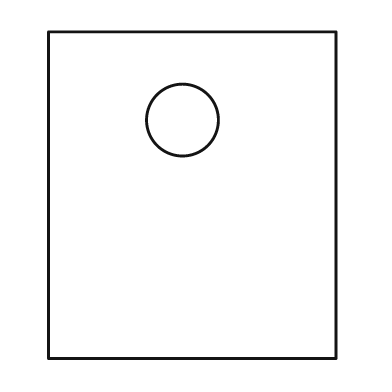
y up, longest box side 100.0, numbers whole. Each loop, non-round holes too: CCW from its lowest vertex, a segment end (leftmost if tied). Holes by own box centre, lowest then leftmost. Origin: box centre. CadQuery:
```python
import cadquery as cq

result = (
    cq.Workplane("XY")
    .moveTo(-44.0, -50.0)
    .lineTo(44.0, -50.0)
    .lineTo(44.0, 50.0)
    .lineTo(-44.0, 50.0)
    .close()
    .moveTo(-3.0, 23.0)
    .circle(11.0)
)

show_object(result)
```